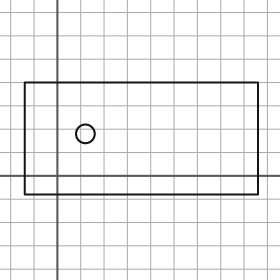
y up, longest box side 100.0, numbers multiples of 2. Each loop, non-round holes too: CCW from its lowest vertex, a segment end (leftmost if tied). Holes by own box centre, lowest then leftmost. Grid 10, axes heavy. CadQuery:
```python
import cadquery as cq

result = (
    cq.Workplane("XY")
    .moveTo(-14.0, -8.0)
    .lineTo(86.0, -8.0)
    .lineTo(86.0, 40.0)
    .lineTo(-14.0, 40.0)
    .close()
    .moveTo(12.0, 18.0)
    .circle(4.0)
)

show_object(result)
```